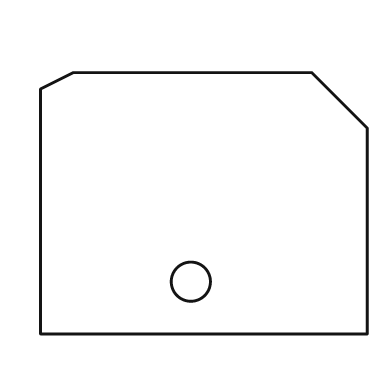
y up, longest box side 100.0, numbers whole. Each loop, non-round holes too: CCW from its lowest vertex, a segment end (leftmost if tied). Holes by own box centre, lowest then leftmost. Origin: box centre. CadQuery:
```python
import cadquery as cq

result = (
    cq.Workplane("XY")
    .moveTo(-50.0, -40.0)
    .lineTo(50.0, -40.0)
    .lineTo(50.0, 23.0)
    .lineTo(33.0, 40.0)
    .lineTo(-40.0, 40.0)
    .lineTo(-50.0, 35.0)
    .close()
    .moveTo(-4.0, -24.0)
    .circle(6.0)
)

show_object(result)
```